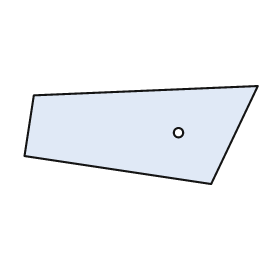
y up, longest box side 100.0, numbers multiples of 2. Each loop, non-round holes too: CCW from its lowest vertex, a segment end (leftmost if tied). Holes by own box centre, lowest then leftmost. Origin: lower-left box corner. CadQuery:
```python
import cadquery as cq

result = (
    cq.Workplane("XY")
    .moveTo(80.0, 0.0)
    .lineTo(100.0, 42.0)
    .lineTo(4.0, 38.0)
    .lineTo(0.0, 12.0)
    .close()
    .moveTo(66.0, 22.0)
    .circle(2.0)
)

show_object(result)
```